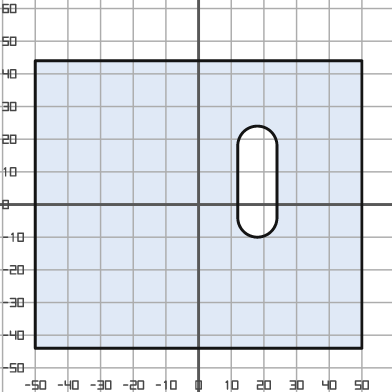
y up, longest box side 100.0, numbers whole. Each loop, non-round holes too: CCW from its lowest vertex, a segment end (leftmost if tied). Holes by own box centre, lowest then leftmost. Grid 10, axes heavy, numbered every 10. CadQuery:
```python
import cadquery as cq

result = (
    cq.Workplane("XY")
    .moveTo(-50.0, -44.0)
    .lineTo(50.0, -44.0)
    .lineTo(50.0, 44.0)
    .lineTo(-50.0, 44.0)
    .close()
    .moveTo(12.0, -4.0)
    .threePointArc((18.0, -10.0), (24.0, -4.0))
    .lineTo(24.0, 18.0)
    .threePointArc((18.0, 24.0), (12.0, 18.0))
    .close()
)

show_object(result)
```